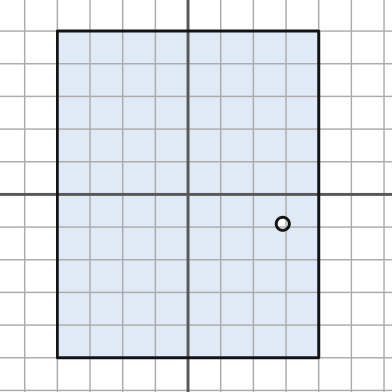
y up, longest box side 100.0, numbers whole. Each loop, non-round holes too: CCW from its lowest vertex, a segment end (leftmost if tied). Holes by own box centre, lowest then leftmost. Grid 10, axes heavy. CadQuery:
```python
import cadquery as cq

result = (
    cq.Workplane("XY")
    .moveTo(-40.0, -50.0)
    .lineTo(40.0, -50.0)
    .lineTo(40.0, 50.0)
    .lineTo(-40.0, 50.0)
    .close()
    .moveTo(29.0, -9.0)
    .circle(2.0)
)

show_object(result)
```